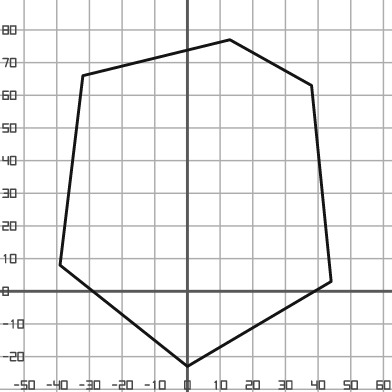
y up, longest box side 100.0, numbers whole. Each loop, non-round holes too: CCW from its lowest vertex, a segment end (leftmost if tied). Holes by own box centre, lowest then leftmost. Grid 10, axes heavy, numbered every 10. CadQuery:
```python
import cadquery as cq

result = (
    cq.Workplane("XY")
    .moveTo(0.0, -23.0)
    .lineTo(44.0, 3.0)
    .lineTo(38.0, 63.0)
    .lineTo(13.0, 77.0)
    .lineTo(-32.0, 66.0)
    .lineTo(-39.0, 8.0)
    .close()
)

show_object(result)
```